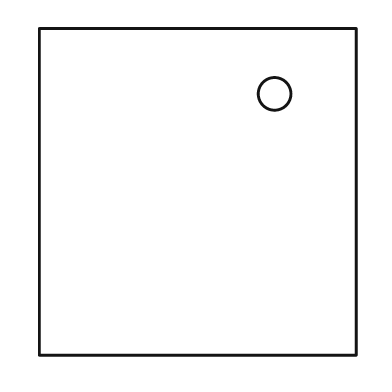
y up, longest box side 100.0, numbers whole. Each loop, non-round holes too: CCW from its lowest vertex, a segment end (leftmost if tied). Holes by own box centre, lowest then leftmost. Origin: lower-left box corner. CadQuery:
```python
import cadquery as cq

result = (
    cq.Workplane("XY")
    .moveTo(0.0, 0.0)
    .lineTo(97.0, 0.0)
    .lineTo(97.0, 100.0)
    .lineTo(0.0, 100.0)
    .close()
    .moveTo(72.0, 80.0)
    .circle(5.0)
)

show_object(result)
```